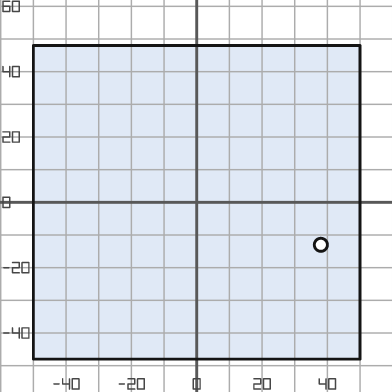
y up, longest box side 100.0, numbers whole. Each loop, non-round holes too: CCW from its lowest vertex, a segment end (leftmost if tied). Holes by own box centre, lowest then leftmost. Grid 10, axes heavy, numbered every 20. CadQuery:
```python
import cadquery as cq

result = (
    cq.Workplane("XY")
    .moveTo(-50.0, -48.0)
    .lineTo(50.0, -48.0)
    .lineTo(50.0, 48.0)
    .lineTo(-50.0, 48.0)
    .close()
    .moveTo(38.0, -13.0)
    .circle(2.0)
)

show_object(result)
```